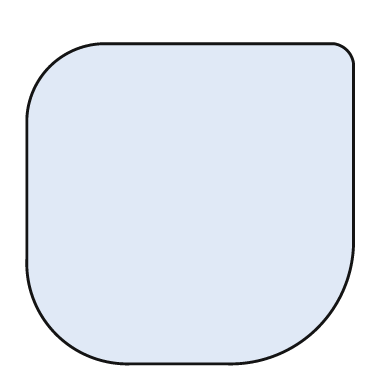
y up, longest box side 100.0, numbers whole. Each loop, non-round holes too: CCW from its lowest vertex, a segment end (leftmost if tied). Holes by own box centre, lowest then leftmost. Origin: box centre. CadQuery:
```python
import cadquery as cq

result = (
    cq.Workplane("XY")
    .moveTo(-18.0, -49.0)
    .lineTo(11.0, -49.0)
    .threePointArc((39.0, -38.0), (50.0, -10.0))
    .lineTo(50.0, 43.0)
    .threePointArc((48.0, 47.0), (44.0, 49.0))
    .lineTo(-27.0, 49.0)
    .threePointArc((-43.0, 42.0), (-50.0, 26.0))
    .lineTo(-50.0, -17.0)
    .threePointArc((-41.0, -40.0), (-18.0, -49.0))
    .close()
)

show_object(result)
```